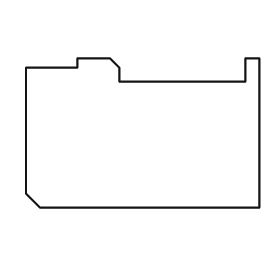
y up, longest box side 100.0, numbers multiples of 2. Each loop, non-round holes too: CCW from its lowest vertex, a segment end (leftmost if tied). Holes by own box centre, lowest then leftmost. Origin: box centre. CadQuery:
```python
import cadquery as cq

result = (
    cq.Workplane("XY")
    .moveTo(-44.0, -32.0)
    .lineTo(50.0, -32.0)
    .lineTo(50.0, 32.0)
    .lineTo(44.0, 32.0)
    .lineTo(44.0, 22.0)
    .lineTo(-10.0, 22.0)
    .lineTo(-10.0, 28.0)
    .lineTo(-14.0, 32.0)
    .lineTo(-28.0, 32.0)
    .lineTo(-28.0, 28.0)
    .lineTo(-50.0, 28.0)
    .lineTo(-50.0, -26.0)
    .close()
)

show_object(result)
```